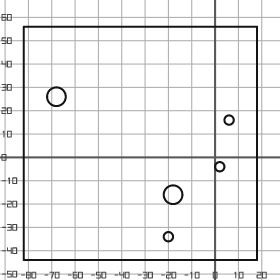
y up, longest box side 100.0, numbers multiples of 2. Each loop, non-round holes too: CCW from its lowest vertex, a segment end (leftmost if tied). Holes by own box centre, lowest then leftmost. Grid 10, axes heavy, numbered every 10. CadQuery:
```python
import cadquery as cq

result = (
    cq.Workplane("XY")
    .moveTo(-82.0, -44.0)
    .lineTo(18.0, -44.0)
    .lineTo(18.0, 56.0)
    .lineTo(-82.0, 56.0)
    .close()
    .moveTo(-20.0, -34.0)
    .circle(2.0)
    .moveTo(-18.0, -16.0)
    .circle(4.0)
    .moveTo(2.0, -4.0)
    .circle(2.0)
    .moveTo(6.0, 16.0)
    .circle(2.0)
    .moveTo(-68.0, 26.0)
    .circle(4.0)
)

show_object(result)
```